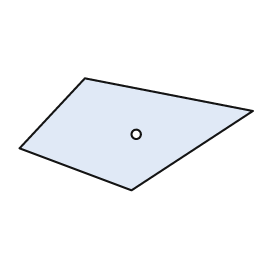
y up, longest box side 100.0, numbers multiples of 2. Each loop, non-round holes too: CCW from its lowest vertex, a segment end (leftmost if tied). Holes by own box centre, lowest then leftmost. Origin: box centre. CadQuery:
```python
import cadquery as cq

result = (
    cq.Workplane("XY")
    .moveTo(-2.0, -24.0)
    .lineTo(50.0, 10.0)
    .lineTo(-22.0, 24.0)
    .lineTo(-50.0, -6.0)
    .close()
    .moveTo(0.0, 0.0)
    .circle(2.0)
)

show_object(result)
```